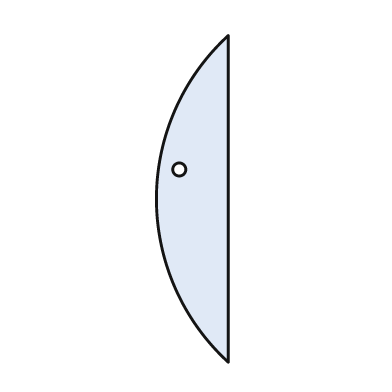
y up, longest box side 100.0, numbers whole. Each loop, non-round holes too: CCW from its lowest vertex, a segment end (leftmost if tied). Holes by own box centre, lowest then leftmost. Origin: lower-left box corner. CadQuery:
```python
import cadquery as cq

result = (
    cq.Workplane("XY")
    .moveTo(22.0, 0.0)
    .lineTo(22.0, 100.0)
    .threePointArc((0.0, 50.0), (22.0, 0.0))
    .close()
    .moveTo(7.0, 59.0)
    .circle(2.0)
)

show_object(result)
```